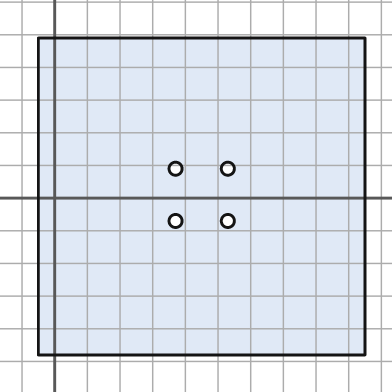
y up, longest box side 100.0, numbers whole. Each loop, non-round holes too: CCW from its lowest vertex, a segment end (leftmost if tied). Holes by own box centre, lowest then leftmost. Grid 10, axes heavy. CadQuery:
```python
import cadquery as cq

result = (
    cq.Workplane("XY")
    .moveTo(-5.0, -48.0)
    .lineTo(95.0, -48.0)
    .lineTo(95.0, 49.0)
    .lineTo(-5.0, 49.0)
    .close()
    .moveTo(37.0, -7.0)
    .circle(2.0)
    .moveTo(53.0, -7.0)
    .circle(2.0)
    .moveTo(37.0, 9.0)
    .circle(2.0)
    .moveTo(53.0, 9.0)
    .circle(2.0)
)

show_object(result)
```